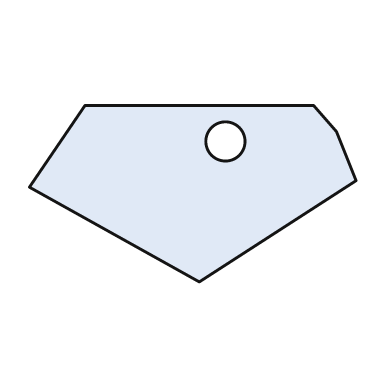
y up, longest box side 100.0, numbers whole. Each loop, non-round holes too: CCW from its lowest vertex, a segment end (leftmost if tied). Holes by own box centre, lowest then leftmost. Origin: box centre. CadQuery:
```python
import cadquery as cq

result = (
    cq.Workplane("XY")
    .moveTo(2.0, -27.0)
    .lineTo(50.0, 4.0)
    .lineTo(44.0, 19.0)
    .lineTo(37.0, 27.0)
    .lineTo(-33.0, 27.0)
    .lineTo(-50.0, 2.0)
    .close()
    .moveTo(10.0, 16.0)
    .circle(6.0)
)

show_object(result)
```